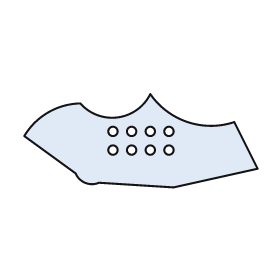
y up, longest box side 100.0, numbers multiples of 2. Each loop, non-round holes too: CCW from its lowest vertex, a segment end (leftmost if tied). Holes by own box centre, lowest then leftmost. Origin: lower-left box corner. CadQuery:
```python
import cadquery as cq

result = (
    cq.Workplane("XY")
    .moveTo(64.0, 0.0)
    .lineTo(100.0, 8.0)
    .lineTo(90.0, 28.0)
    .threePointArc((70.0, 28.0), (54.0, 40.0))
    .threePointArc((40.0, 30.0), (24.0, 36.0))
    .threePointArc((10.0, 32.0), (0.0, 22.0))
    .lineTo(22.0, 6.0)
    .threePointArc((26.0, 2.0), (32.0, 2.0))
    .close()
    .moveTo(38.0, 16.0)
    .circle(2.0)
    .moveTo(46.0, 16.0)
    .circle(2.0)
    .moveTo(54.0, 16.0)
    .circle(2.0)
    .moveTo(62.0, 16.0)
    .circle(2.0)
    .moveTo(38.0, 24.0)
    .circle(2.0)
    .moveTo(46.0, 24.0)
    .circle(2.0)
    .moveTo(54.0, 24.0)
    .circle(2.0)
    .moveTo(62.0, 24.0)
    .circle(2.0)
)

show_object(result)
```